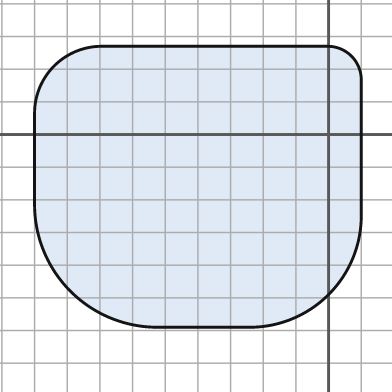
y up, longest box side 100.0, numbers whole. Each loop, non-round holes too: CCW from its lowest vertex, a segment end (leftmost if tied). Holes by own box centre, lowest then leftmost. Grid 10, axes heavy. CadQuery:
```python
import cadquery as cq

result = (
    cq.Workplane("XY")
    .moveTo(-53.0, -59.0)
    .lineTo(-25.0, -59.0)
    .threePointArc((0.0, -49.0), (10.0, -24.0))
    .lineTo(10.0, 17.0)
    .threePointArc((7.0, 24.0), (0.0, 27.0))
    .lineTo(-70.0, 27.0)
    .threePointArc((-84.0, 21.0), (-90.0, 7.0))
    .lineTo(-90.0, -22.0)
    .threePointArc((-79.0, -48.0), (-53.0, -59.0))
    .close()
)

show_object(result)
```